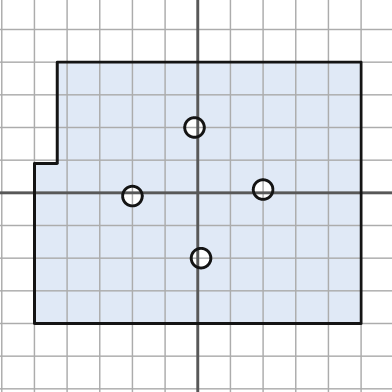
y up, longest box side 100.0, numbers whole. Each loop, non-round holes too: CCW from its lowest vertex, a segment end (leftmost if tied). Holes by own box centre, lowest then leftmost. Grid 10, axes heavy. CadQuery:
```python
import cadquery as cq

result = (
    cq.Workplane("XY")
    .moveTo(-50.0, -40.0)
    .lineTo(50.0, -40.0)
    .lineTo(50.0, 40.0)
    .lineTo(-43.0, 40.0)
    .lineTo(-43.0, 9.0)
    .lineTo(-50.0, 9.0)
    .close()
    .moveTo(1.0, -20.0)
    .circle(3.0)
    .moveTo(-20.0, -1.0)
    .circle(3.0)
    .moveTo(20.0, 1.0)
    .circle(3.0)
    .moveTo(-1.0, 20.0)
    .circle(3.0)
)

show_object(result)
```